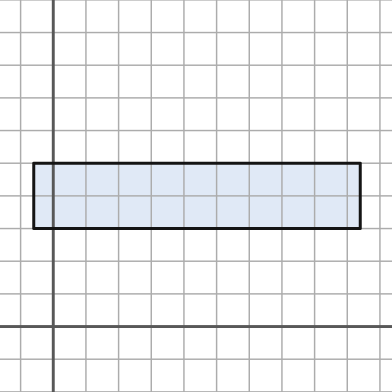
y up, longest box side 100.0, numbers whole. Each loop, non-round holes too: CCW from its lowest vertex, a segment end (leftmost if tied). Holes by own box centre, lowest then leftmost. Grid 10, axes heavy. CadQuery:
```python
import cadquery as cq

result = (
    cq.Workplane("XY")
    .moveTo(-6.0, 30.0)
    .lineTo(94.0, 30.0)
    .lineTo(94.0, 50.0)
    .lineTo(-6.0, 50.0)
    .close()
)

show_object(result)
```